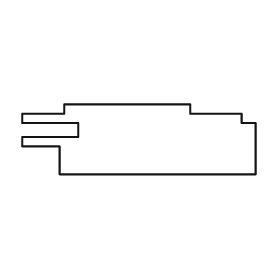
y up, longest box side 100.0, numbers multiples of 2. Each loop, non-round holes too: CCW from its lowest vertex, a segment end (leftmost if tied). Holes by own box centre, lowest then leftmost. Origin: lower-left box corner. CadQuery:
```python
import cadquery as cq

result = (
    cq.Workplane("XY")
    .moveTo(16.0, 0.0)
    .lineTo(100.0, 0.0)
    .lineTo(100.0, 22.0)
    .lineTo(94.0, 22.0)
    .lineTo(94.0, 26.0)
    .lineTo(72.0, 26.0)
    .lineTo(72.0, 30.0)
    .lineTo(18.0, 30.0)
    .lineTo(18.0, 26.0)
    .lineTo(0.0, 26.0)
    .lineTo(0.0, 22.0)
    .lineTo(24.0, 22.0)
    .lineTo(24.0, 16.0)
    .lineTo(0.0, 16.0)
    .lineTo(0.0, 12.0)
    .lineTo(16.0, 12.0)
    .close()
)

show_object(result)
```